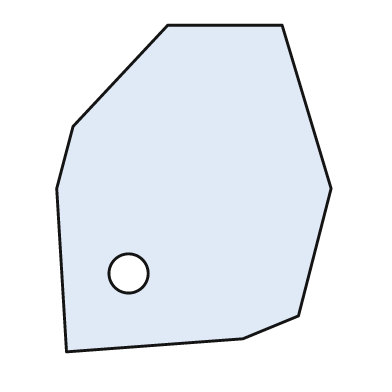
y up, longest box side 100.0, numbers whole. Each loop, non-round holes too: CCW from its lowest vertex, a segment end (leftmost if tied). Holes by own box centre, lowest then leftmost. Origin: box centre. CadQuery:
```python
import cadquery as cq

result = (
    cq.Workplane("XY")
    .moveTo(-39.0, -50.0)
    .lineTo(15.0, -46.0)
    .lineTo(32.0, -39.0)
    .lineTo(42.0, 0.0)
    .lineTo(27.0, 50.0)
    .lineTo(-8.0, 50.0)
    .lineTo(-37.0, 19.0)
    .lineTo(-42.0, 0.0)
    .close()
    .moveTo(-20.0, -26.0)
    .circle(6.0)
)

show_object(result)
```